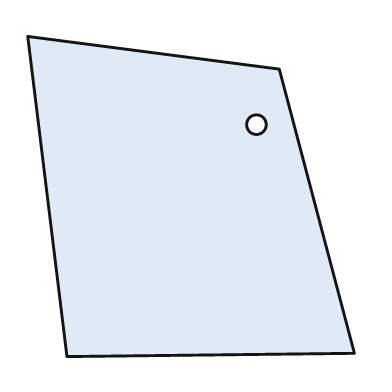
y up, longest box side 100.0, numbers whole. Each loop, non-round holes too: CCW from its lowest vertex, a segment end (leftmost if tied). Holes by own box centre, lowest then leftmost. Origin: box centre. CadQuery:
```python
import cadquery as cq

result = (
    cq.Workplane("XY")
    .moveTo(-38.0, -49.0)
    .lineTo(50.0, -48.0)
    .lineTo(27.0, 39.0)
    .lineTo(-50.0, 49.0)
    .close()
    .moveTo(20.0, 22.0)
    .circle(3.0)
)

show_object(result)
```